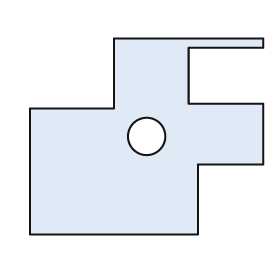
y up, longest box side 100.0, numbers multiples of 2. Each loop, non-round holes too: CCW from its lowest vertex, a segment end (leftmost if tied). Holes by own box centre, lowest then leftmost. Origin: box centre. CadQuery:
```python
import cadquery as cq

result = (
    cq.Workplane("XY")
    .moveTo(-50.0, -42.0)
    .lineTo(22.0, -42.0)
    .lineTo(22.0, -12.0)
    .lineTo(50.0, -12.0)
    .lineTo(50.0, 14.0)
    .lineTo(18.0, 14.0)
    .lineTo(18.0, 38.0)
    .lineTo(50.0, 38.0)
    .lineTo(50.0, 42.0)
    .lineTo(-14.0, 42.0)
    .lineTo(-14.0, 12.0)
    .lineTo(-50.0, 12.0)
    .close()
    .moveTo(0.0, 0.0)
    .circle(8.0)
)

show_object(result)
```